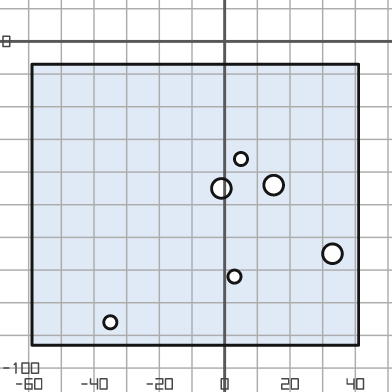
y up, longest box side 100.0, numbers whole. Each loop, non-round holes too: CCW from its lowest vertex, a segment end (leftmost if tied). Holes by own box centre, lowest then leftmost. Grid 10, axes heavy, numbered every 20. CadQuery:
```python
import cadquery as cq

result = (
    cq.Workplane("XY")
    .moveTo(-59.0, -93.0)
    .lineTo(41.0, -93.0)
    .lineTo(41.0, -7.0)
    .lineTo(-59.0, -7.0)
    .close()
    .moveTo(-35.0, -86.0)
    .circle(2.0)
    .moveTo(3.0, -72.0)
    .circle(2.0)
    .moveTo(33.0, -65.0)
    .circle(3.0)
    .moveTo(-1.0, -45.0)
    .circle(3.0)
    .moveTo(15.0, -44.0)
    .circle(3.0)
    .moveTo(5.0, -36.0)
    .circle(2.0)
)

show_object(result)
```